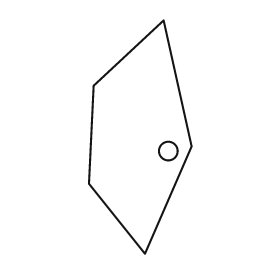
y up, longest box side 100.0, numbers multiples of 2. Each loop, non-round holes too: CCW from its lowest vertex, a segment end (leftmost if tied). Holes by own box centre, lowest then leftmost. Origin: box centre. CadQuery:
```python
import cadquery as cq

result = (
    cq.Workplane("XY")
    .moveTo(2.0, -50.0)
    .lineTo(22.0, -4.0)
    .lineTo(10.0, 50.0)
    .lineTo(-20.0, 22.0)
    .lineTo(-22.0, -20.0)
    .close()
    .moveTo(12.0, -6.0)
    .circle(4.0)
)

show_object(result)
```